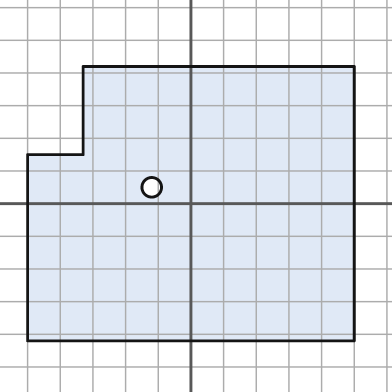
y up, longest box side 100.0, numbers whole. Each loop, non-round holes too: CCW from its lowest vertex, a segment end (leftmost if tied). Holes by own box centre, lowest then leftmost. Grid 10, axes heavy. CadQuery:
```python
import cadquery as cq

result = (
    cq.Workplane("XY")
    .moveTo(-50.0, -42.0)
    .lineTo(50.0, -42.0)
    .lineTo(50.0, 42.0)
    .lineTo(-33.0, 42.0)
    .lineTo(-33.0, 15.0)
    .lineTo(-50.0, 15.0)
    .close()
    .moveTo(-12.0, 5.0)
    .circle(3.0)
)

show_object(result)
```